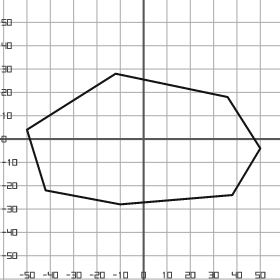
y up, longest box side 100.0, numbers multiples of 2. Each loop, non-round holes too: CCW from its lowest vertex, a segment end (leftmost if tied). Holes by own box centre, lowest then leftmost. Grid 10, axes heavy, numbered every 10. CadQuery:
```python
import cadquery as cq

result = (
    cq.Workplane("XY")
    .moveTo(-10.0, -28.0)
    .lineTo(38.0, -24.0)
    .lineTo(50.0, -4.0)
    .lineTo(36.0, 18.0)
    .lineTo(-12.0, 28.0)
    .lineTo(-50.0, 4.0)
    .lineTo(-42.0, -22.0)
    .close()
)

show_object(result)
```